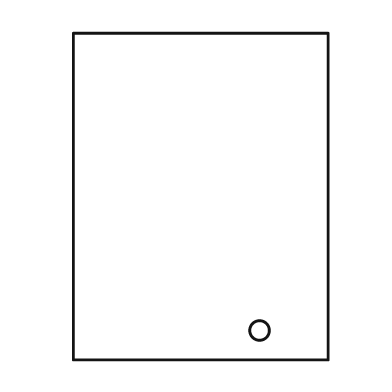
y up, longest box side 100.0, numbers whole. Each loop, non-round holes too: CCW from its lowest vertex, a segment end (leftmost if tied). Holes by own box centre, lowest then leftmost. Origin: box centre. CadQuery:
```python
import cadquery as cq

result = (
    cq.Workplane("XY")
    .moveTo(-39.0, -50.0)
    .lineTo(39.0, -50.0)
    .lineTo(39.0, 50.0)
    .lineTo(-39.0, 50.0)
    .close()
    .moveTo(18.0, -41.0)
    .circle(3.0)
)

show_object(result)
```